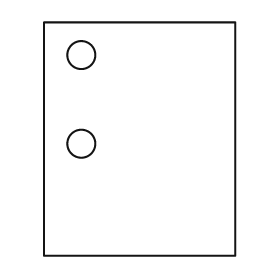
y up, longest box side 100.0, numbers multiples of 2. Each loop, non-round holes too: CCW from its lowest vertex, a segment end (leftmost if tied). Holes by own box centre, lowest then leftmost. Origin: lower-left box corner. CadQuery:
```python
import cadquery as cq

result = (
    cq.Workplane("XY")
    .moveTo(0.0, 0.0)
    .lineTo(82.0, 0.0)
    .lineTo(82.0, 100.0)
    .lineTo(0.0, 100.0)
    .close()
    .moveTo(16.0, 48.0)
    .circle(6.0)
    .moveTo(16.0, 86.0)
    .circle(6.0)
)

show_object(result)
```